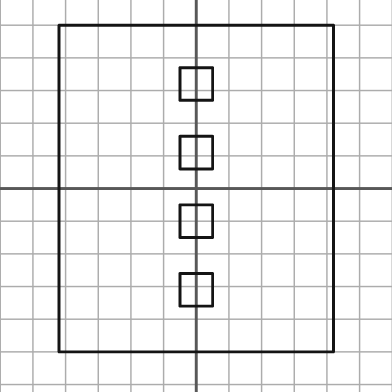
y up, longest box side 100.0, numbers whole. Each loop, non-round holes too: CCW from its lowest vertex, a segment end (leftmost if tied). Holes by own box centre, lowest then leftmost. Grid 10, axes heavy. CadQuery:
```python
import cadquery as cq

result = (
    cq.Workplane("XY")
    .moveTo(-42.0, -50.0)
    .lineTo(42.0, -50.0)
    .lineTo(42.0, 50.0)
    .lineTo(-42.0, 50.0)
    .close()
    .moveTo(-5.0, -36.0)
    .lineTo(5.0, -36.0)
    .lineTo(5.0, -26.0)
    .lineTo(-5.0, -26.0)
    .close()
    .moveTo(-5.0, -15.0)
    .lineTo(5.0, -15.0)
    .lineTo(5.0, -5.0)
    .lineTo(-5.0, -5.0)
    .close()
    .moveTo(-5.0, 6.0)
    .lineTo(5.0, 6.0)
    .lineTo(5.0, 16.0)
    .lineTo(-5.0, 16.0)
    .close()
    .moveTo(-5.0, 27.0)
    .lineTo(5.0, 27.0)
    .lineTo(5.0, 37.0)
    .lineTo(-5.0, 37.0)
    .close()
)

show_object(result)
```